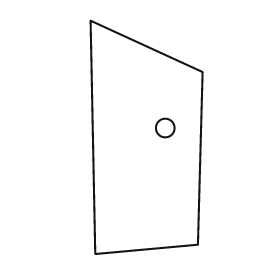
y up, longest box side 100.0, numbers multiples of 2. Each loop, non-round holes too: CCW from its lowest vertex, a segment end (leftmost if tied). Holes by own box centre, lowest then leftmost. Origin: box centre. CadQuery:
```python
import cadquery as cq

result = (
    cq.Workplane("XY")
    .moveTo(-22.0, -50.0)
    .lineTo(22.0, -46.0)
    .lineTo(24.0, 28.0)
    .lineTo(-24.0, 50.0)
    .close()
    .moveTo(8.0, 4.0)
    .circle(4.0)
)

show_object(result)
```